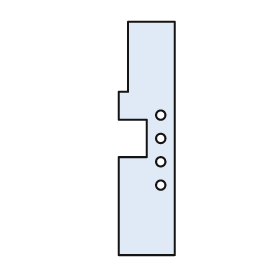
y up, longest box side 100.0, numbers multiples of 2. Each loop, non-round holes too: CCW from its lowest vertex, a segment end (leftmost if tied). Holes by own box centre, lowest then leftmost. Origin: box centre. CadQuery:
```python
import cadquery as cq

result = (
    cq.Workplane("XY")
    .moveTo(-12.0, -50.0)
    .lineTo(12.0, -50.0)
    .lineTo(12.0, 50.0)
    .lineTo(-8.0, 50.0)
    .lineTo(-8.0, 20.0)
    .lineTo(-12.0, 20.0)
    .lineTo(-12.0, 8.0)
    .lineTo(0.0, 8.0)
    .lineTo(0.0, -8.0)
    .lineTo(-12.0, -8.0)
    .close()
    .moveTo(6.0, -20.0)
    .circle(2.0)
    .moveTo(6.0, -10.0)
    .circle(2.0)
    .moveTo(6.0, 0.0)
    .circle(2.0)
    .moveTo(6.0, 10.0)
    .circle(2.0)
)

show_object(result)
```